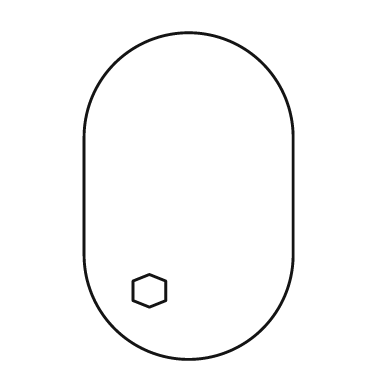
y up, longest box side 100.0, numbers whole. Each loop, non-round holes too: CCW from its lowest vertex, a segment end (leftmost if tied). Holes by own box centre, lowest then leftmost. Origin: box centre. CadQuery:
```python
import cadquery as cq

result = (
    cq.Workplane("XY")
    .moveTo(-32.0, -18.0)
    .threePointArc((0.0, -50.0), (32.0, -18.0))
    .lineTo(32.0, 18.0)
    .threePointArc((0.0, 50.0), (-32.0, 18.0))
    .close()
    .moveTo(-12.0, -34.0)
    .lineTo(-7.0, -32.0)
    .lineTo(-7.0, -26.0)
    .lineTo(-12.0, -24.0)
    .lineTo(-17.0, -26.0)
    .lineTo(-17.0, -32.0)
    .close()
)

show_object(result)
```